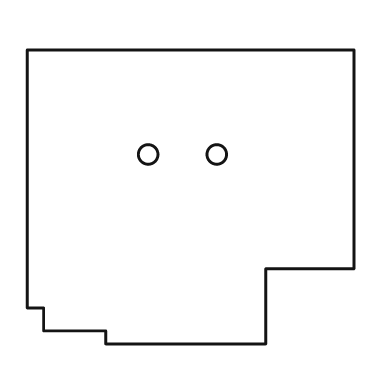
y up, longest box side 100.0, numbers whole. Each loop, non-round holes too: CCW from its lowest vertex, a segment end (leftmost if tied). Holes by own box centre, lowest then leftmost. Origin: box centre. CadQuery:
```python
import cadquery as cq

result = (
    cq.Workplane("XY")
    .moveTo(-26.0, -45.0)
    .lineTo(23.0, -45.0)
    .lineTo(23.0, -22.0)
    .lineTo(50.0, -22.0)
    .lineTo(50.0, 45.0)
    .lineTo(-50.0, 45.0)
    .lineTo(-50.0, -34.0)
    .lineTo(-45.0, -34.0)
    .lineTo(-45.0, -41.0)
    .lineTo(-26.0, -41.0)
    .close()
    .moveTo(-13.0, 13.0)
    .circle(3.0)
    .moveTo(8.0, 13.0)
    .circle(3.0)
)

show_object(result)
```